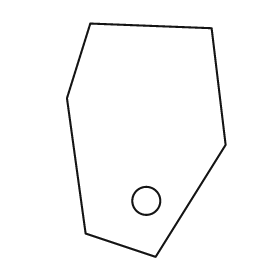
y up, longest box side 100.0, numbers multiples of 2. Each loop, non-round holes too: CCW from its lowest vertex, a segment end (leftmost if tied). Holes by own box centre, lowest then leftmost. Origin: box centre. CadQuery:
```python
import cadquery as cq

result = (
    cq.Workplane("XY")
    .moveTo(4.0, -50.0)
    .lineTo(34.0, -2.0)
    .lineTo(28.0, 48.0)
    .lineTo(-24.0, 50.0)
    .lineTo(-34.0, 18.0)
    .lineTo(-26.0, -40.0)
    .close()
    .moveTo(0.0, -26.0)
    .circle(6.0)
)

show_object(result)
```